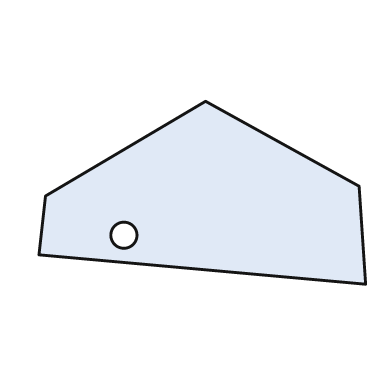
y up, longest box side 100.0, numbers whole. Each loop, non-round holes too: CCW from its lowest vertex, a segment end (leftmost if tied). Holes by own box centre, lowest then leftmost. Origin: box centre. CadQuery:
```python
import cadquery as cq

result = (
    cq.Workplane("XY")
    .moveTo(50.0, -28.0)
    .lineTo(48.0, 2.0)
    .lineTo(1.0, 28.0)
    .lineTo(-48.0, -1.0)
    .lineTo(-50.0, -19.0)
    .close()
    .moveTo(-24.0, -13.0)
    .circle(4.0)
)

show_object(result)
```